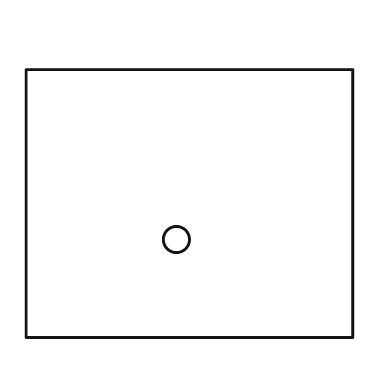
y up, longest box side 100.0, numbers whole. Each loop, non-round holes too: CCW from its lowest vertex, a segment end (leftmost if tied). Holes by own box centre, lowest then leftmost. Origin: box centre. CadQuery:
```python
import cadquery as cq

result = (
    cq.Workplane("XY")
    .moveTo(-50.0, -41.0)
    .lineTo(50.0, -41.0)
    .lineTo(50.0, 41.0)
    .lineTo(-50.0, 41.0)
    .close()
    .moveTo(-4.0, -11.0)
    .circle(4.0)
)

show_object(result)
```